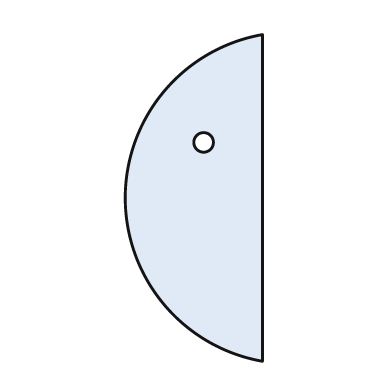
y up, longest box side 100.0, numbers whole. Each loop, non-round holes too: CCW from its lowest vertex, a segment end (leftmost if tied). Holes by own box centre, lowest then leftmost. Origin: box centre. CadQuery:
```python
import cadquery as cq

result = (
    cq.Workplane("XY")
    .moveTo(21.0, -50.0)
    .lineTo(21.0, 50.0)
    .threePointArc((-21.0, 0.0), (21.0, -50.0))
    .close()
    .moveTo(3.0, 17.0)
    .circle(3.0)
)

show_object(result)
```